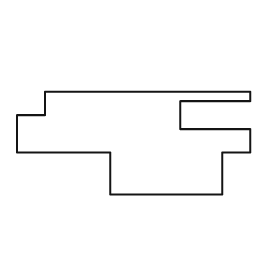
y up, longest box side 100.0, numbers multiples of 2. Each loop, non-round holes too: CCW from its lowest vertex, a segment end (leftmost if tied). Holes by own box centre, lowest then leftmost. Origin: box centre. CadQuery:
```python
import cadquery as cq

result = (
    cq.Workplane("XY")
    .moveTo(-10.0, -22.0)
    .lineTo(38.0, -22.0)
    .lineTo(38.0, -4.0)
    .lineTo(50.0, -4.0)
    .lineTo(50.0, 6.0)
    .lineTo(20.0, 6.0)
    .lineTo(20.0, 18.0)
    .lineTo(50.0, 18.0)
    .lineTo(50.0, 22.0)
    .lineTo(-38.0, 22.0)
    .lineTo(-38.0, 12.0)
    .lineTo(-50.0, 12.0)
    .lineTo(-50.0, -4.0)
    .lineTo(-10.0, -4.0)
    .close()
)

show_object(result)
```